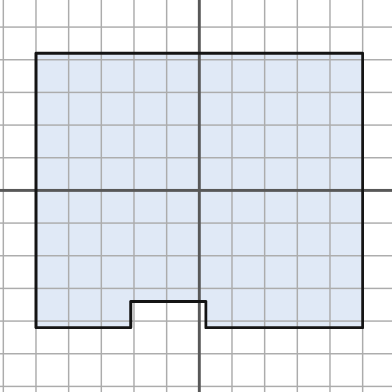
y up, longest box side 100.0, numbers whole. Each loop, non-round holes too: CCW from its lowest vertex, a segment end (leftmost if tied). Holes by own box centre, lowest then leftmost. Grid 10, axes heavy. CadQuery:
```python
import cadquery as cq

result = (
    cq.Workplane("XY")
    .moveTo(-50.0, -42.0)
    .lineTo(-21.0, -42.0)
    .lineTo(-21.0, -34.0)
    .lineTo(2.0, -34.0)
    .lineTo(2.0, -42.0)
    .lineTo(50.0, -42.0)
    .lineTo(50.0, 42.0)
    .lineTo(-50.0, 42.0)
    .close()
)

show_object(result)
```